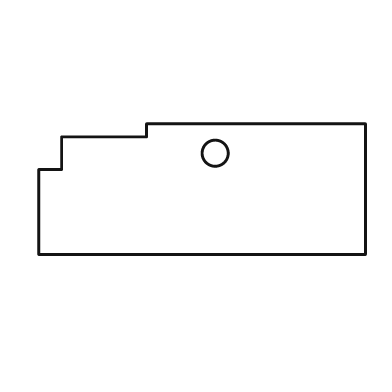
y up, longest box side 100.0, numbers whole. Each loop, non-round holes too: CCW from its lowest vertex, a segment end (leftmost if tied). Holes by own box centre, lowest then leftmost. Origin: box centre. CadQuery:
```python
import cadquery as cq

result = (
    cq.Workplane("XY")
    .moveTo(-50.0, -20.0)
    .lineTo(50.0, -20.0)
    .lineTo(50.0, 20.0)
    .lineTo(-17.0, 20.0)
    .lineTo(-17.0, 16.0)
    .lineTo(-43.0, 16.0)
    .lineTo(-43.0, 6.0)
    .lineTo(-50.0, 6.0)
    .close()
    .moveTo(4.0, 11.0)
    .circle(4.0)
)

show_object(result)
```